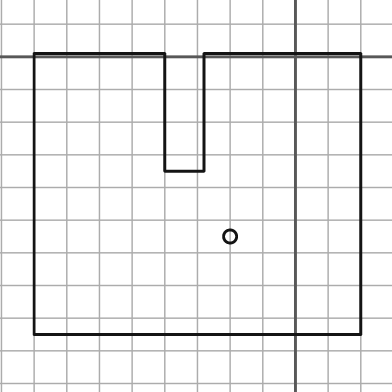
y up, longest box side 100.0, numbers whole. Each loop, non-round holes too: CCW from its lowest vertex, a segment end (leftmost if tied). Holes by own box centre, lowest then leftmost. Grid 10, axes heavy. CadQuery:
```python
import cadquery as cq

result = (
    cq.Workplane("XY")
    .moveTo(-80.0, -85.0)
    .lineTo(20.0, -85.0)
    .lineTo(20.0, 1.0)
    .lineTo(-28.0, 1.0)
    .lineTo(-28.0, -35.0)
    .lineTo(-40.0, -35.0)
    .lineTo(-40.0, 1.0)
    .lineTo(-80.0, 1.0)
    .close()
    .moveTo(-20.0, -55.0)
    .circle(2.0)
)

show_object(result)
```